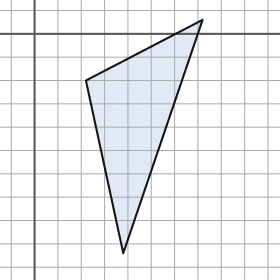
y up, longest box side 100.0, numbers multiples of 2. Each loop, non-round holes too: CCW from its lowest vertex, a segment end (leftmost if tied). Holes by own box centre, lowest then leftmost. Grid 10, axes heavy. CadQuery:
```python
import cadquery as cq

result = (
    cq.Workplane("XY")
    .moveTo(38.0, -94.0)
    .lineTo(72.0, 6.0)
    .lineTo(22.0, -20.0)
    .close()
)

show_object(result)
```